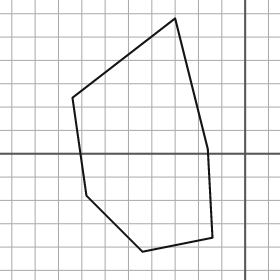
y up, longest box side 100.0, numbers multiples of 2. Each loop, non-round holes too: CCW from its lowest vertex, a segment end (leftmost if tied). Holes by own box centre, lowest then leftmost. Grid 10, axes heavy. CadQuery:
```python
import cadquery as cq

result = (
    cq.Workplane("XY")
    .moveTo(-44.0, -42.0)
    .lineTo(-14.0, -36.0)
    .lineTo(-16.0, 2.0)
    .lineTo(-30.0, 58.0)
    .lineTo(-74.0, 24.0)
    .lineTo(-68.0, -18.0)
    .close()
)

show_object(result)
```